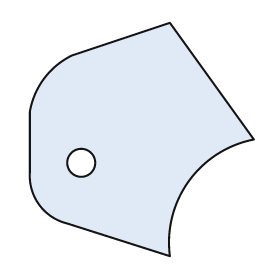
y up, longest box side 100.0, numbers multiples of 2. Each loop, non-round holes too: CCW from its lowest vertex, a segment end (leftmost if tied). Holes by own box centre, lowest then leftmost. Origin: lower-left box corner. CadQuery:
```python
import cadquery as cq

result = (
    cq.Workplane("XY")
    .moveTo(60.0, 0.0)
    .threePointArc((68.0, 32.0), (96.0, 50.0))
    .lineTo(60.0, 100.0)
    .lineTo(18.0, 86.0)
    .threePointArc((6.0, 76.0), (0.0, 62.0))
    .lineTo(0.0, 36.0)
    .threePointArc((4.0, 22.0), (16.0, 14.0))
    .close()
    .moveTo(22.0, 40.0)
    .circle(6.0)
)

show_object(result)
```